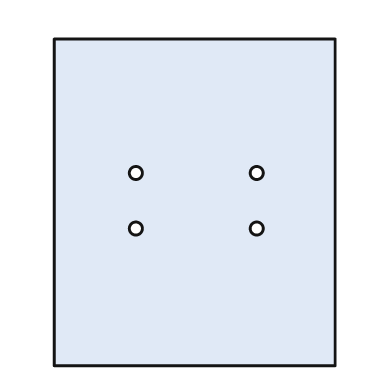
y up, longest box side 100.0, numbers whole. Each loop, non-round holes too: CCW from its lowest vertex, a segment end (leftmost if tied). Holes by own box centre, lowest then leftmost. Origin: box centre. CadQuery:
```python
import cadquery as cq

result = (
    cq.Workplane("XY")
    .moveTo(-43.0, -50.0)
    .lineTo(43.0, -50.0)
    .lineTo(43.0, 50.0)
    .lineTo(-43.0, 50.0)
    .close()
    .moveTo(-18.0, -8.0)
    .circle(2.0)
    .moveTo(19.0, -8.0)
    .circle(2.0)
    .moveTo(-18.0, 9.0)
    .circle(2.0)
    .moveTo(19.0, 9.0)
    .circle(2.0)
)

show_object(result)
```